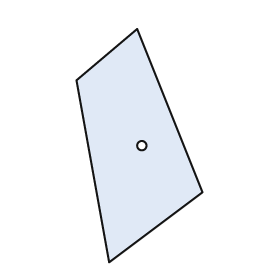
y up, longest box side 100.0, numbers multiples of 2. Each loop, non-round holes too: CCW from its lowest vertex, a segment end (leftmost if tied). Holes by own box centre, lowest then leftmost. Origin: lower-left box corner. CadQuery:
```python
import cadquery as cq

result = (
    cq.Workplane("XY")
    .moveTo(14.0, 0.0)
    .lineTo(54.0, 30.0)
    .lineTo(26.0, 100.0)
    .lineTo(0.0, 78.0)
    .close()
    .moveTo(28.0, 50.0)
    .circle(2.0)
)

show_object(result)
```